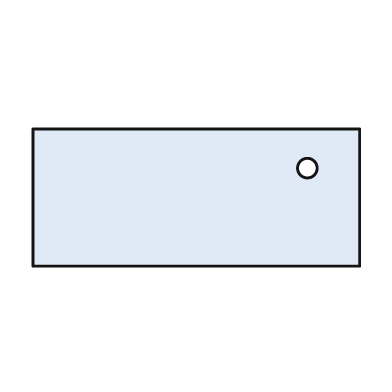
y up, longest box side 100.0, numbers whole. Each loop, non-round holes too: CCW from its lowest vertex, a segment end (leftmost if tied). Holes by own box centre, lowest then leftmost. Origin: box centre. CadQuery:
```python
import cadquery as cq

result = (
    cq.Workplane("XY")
    .moveTo(-50.0, -21.0)
    .lineTo(50.0, -21.0)
    .lineTo(50.0, 21.0)
    .lineTo(-50.0, 21.0)
    .close()
    .moveTo(34.0, 9.0)
    .circle(3.0)
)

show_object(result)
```